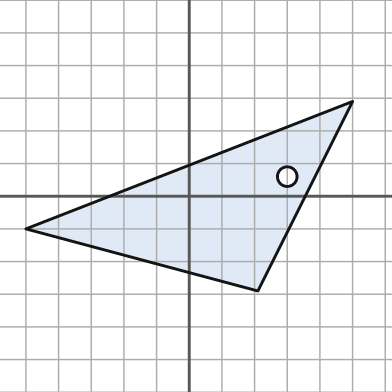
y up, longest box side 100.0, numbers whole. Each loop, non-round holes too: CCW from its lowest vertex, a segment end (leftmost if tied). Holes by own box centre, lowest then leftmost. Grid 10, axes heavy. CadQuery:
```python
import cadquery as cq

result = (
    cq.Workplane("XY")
    .moveTo(21.0, -29.0)
    .lineTo(50.0, 29.0)
    .lineTo(-50.0, -10.0)
    .close()
    .moveTo(30.0, 6.0)
    .circle(3.0)
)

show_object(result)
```